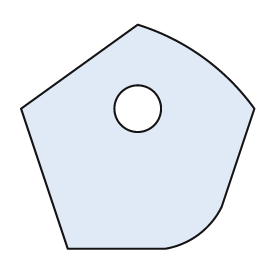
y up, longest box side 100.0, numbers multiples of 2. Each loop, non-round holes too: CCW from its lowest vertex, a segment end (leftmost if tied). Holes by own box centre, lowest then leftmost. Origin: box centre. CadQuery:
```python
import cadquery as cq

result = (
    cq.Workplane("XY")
    .moveTo(-30.0, -48.0)
    .lineTo(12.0, -48.0)
    .threePointArc((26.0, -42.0), (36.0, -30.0))
    .lineTo(50.0, 12.0)
    .threePointArc((28.0, 34.0), (0.0, 48.0))
    .lineTo(-50.0, 12.0)
    .close()
    .moveTo(0.0, 12.0)
    .circle(10.0)
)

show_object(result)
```